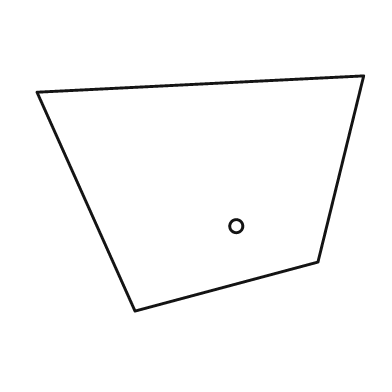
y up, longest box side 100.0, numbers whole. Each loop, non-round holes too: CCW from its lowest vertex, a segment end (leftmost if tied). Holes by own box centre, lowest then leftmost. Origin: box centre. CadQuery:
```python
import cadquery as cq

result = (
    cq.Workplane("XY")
    .moveTo(-20.0, -36.0)
    .lineTo(36.0, -21.0)
    .lineTo(50.0, 36.0)
    .lineTo(-50.0, 31.0)
    .close()
    .moveTo(11.0, -10.0)
    .circle(2.0)
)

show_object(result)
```